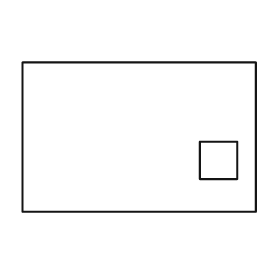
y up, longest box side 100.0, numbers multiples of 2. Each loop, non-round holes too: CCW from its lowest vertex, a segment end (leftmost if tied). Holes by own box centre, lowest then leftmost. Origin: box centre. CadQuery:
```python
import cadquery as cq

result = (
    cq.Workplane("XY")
    .moveTo(-50.0, -32.0)
    .lineTo(50.0, -32.0)
    .lineTo(50.0, 32.0)
    .lineTo(-50.0, 32.0)
    .close()
    .moveTo(26.0, -18.0)
    .lineTo(42.0, -18.0)
    .lineTo(42.0, -2.0)
    .lineTo(26.0, -2.0)
    .close()
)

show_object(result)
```